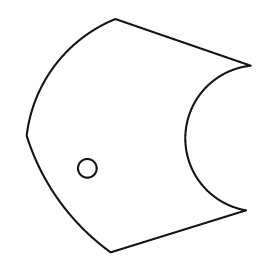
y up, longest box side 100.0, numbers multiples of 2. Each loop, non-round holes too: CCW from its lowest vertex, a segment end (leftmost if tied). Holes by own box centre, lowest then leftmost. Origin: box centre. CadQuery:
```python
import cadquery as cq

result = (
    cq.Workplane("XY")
    .moveTo(-12.0, -50.0)
    .lineTo(46.0, -32.0)
    .threePointArc((20.0, 0.0), (48.0, 30.0))
    .lineTo(-10.0, 50.0)
    .threePointArc((-36.0, 30.0), (-48.0, 0.0))
    .threePointArc((-34.0, -28.0), (-12.0, -50.0))
    .close()
    .moveTo(-22.0, -14.0)
    .circle(4.0)
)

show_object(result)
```